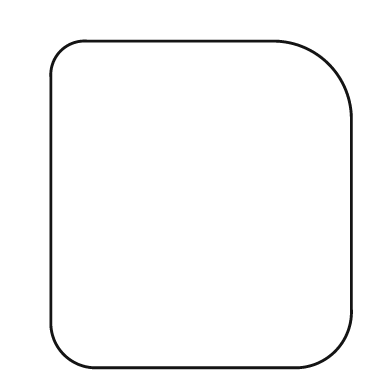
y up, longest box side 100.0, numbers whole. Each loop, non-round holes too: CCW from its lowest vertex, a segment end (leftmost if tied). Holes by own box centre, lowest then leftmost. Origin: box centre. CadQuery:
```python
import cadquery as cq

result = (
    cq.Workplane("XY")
    .moveTo(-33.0, -50.0)
    .lineTo(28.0, -50.0)
    .threePointArc((41.0, -45.0), (46.0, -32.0))
    .lineTo(46.0, 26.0)
    .threePointArc((39.0, 43.0), (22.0, 50.0))
    .lineTo(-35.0, 50.0)
    .threePointArc((-43.0, 47.0), (-46.0, 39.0))
    .lineTo(-46.0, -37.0)
    .threePointArc((-42.0, -46.0), (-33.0, -50.0))
    .close()
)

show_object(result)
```